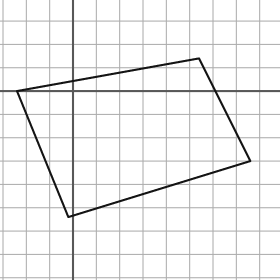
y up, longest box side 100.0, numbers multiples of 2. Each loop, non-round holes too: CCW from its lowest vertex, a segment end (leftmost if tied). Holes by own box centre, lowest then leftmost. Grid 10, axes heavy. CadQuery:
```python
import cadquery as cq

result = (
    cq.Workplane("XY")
    .moveTo(-2.0, -54.0)
    .lineTo(76.0, -30.0)
    .lineTo(54.0, 14.0)
    .lineTo(-24.0, 0.0)
    .close()
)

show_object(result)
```